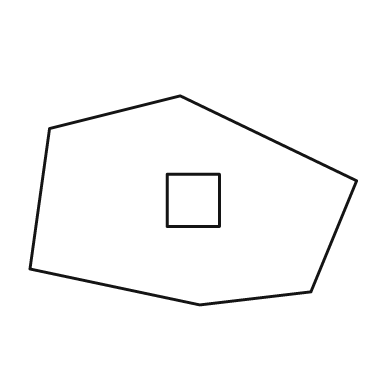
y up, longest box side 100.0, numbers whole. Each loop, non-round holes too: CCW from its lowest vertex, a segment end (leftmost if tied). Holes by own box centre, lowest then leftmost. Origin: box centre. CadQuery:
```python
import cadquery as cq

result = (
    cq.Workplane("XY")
    .moveTo(2.0, -32.0)
    .lineTo(36.0, -28.0)
    .lineTo(50.0, 6.0)
    .lineTo(-4.0, 32.0)
    .lineTo(-44.0, 22.0)
    .lineTo(-50.0, -21.0)
    .close()
    .moveTo(-8.0, -8.0)
    .lineTo(8.0, -8.0)
    .lineTo(8.0, 8.0)
    .lineTo(-8.0, 8.0)
    .close()
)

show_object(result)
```